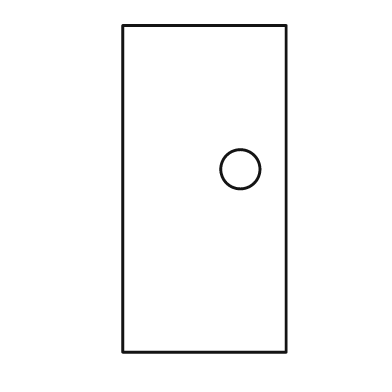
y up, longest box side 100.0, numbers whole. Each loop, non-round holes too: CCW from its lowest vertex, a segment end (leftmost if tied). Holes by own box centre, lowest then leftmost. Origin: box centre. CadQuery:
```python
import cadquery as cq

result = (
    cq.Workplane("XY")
    .moveTo(-25.0, -50.0)
    .lineTo(25.0, -50.0)
    .lineTo(25.0, 50.0)
    .lineTo(-25.0, 50.0)
    .close()
    .moveTo(11.0, 6.0)
    .circle(6.0)
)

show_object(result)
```